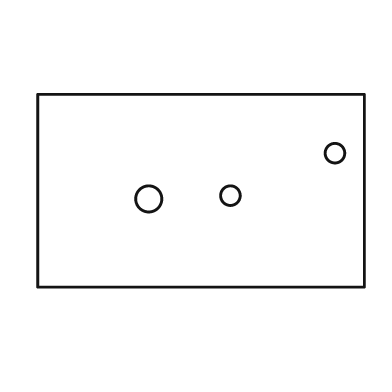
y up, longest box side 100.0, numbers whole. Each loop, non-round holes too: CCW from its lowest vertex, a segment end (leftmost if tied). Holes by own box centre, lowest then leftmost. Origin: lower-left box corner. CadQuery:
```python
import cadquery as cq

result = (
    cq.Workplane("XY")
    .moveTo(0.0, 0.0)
    .lineTo(100.0, 0.0)
    .lineTo(100.0, 59.0)
    .lineTo(0.0, 59.0)
    .close()
    .moveTo(34.0, 27.0)
    .circle(4.0)
    .moveTo(59.0, 28.0)
    .circle(3.0)
    .moveTo(91.0, 41.0)
    .circle(3.0)
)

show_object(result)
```